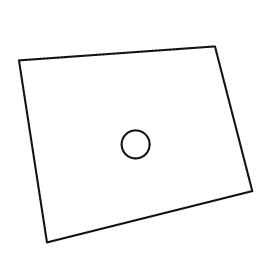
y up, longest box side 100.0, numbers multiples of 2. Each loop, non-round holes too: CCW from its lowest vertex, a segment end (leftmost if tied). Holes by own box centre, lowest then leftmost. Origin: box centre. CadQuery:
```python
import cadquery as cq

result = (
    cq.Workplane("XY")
    .moveTo(-38.0, -42.0)
    .lineTo(50.0, -20.0)
    .lineTo(34.0, 42.0)
    .lineTo(-50.0, 36.0)
    .close()
    .moveTo(0.0, 0.0)
    .circle(6.0)
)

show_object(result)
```